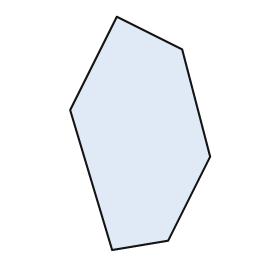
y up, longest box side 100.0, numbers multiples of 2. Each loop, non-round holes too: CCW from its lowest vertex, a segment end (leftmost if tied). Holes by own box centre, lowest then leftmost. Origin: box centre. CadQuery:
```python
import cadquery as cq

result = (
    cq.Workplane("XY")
    .moveTo(-12.0, -50.0)
    .lineTo(12.0, -46.0)
    .lineTo(30.0, -10.0)
    .lineTo(18.0, 36.0)
    .lineTo(-10.0, 50.0)
    .lineTo(-30.0, 10.0)
    .close()
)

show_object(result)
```